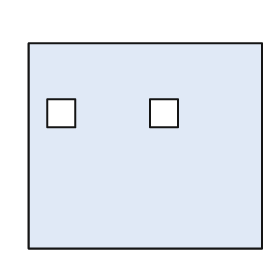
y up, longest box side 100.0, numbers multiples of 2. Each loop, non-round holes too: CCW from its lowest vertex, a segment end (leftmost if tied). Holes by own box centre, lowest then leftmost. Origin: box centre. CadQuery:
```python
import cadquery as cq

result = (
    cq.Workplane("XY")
    .moveTo(-50.0, -44.0)
    .lineTo(50.0, -44.0)
    .lineTo(50.0, 44.0)
    .lineTo(-50.0, 44.0)
    .close()
    .moveTo(-42.0, 8.0)
    .lineTo(-30.0, 8.0)
    .lineTo(-30.0, 20.0)
    .lineTo(-42.0, 20.0)
    .close()
    .moveTo(2.0, 8.0)
    .lineTo(14.0, 8.0)
    .lineTo(14.0, 20.0)
    .lineTo(2.0, 20.0)
    .close()
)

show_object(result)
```